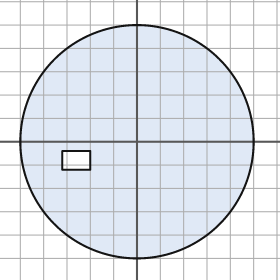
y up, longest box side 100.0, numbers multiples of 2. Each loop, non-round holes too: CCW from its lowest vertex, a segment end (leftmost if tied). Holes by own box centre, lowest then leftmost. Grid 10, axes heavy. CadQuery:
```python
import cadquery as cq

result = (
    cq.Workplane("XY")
    .moveTo(0.0, 0.0)
    .circle(50.0)
    .moveTo(-32.0, -12.0)
    .lineTo(-20.0, -12.0)
    .lineTo(-20.0, -4.0)
    .lineTo(-32.0, -4.0)
    .close()
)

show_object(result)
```